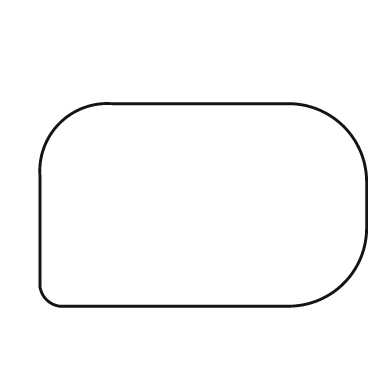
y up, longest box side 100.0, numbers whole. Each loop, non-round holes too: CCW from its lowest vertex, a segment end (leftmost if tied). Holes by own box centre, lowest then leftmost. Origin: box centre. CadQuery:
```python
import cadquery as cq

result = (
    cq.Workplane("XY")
    .moveTo(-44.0, -31.0)
    .lineTo(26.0, -31.0)
    .threePointArc((43.0, -24.0), (50.0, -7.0))
    .lineTo(50.0, 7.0)
    .threePointArc((43.0, 24.0), (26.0, 31.0))
    .lineTo(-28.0, 31.0)
    .threePointArc((-44.0, 25.0), (-50.0, 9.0))
    .lineTo(-50.0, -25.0)
    .threePointArc((-48.0, -29.0), (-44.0, -31.0))
    .close()
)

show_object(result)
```